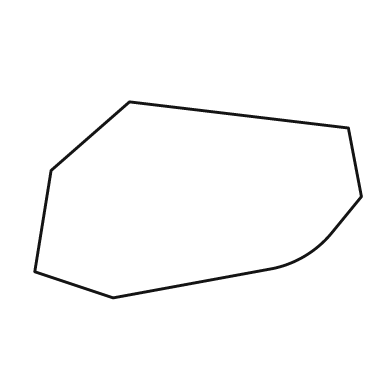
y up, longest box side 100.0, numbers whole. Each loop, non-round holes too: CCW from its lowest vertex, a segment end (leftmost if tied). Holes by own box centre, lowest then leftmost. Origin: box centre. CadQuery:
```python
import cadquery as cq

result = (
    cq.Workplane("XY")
    .moveTo(-26.0, -30.0)
    .lineTo(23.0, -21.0)
    .threePointArc((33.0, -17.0), (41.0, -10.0))
    .lineTo(50.0, 1.0)
    .lineTo(46.0, 22.0)
    .lineTo(-21.0, 30.0)
    .lineTo(-45.0, 9.0)
    .lineTo(-50.0, -22.0)
    .close()
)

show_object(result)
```